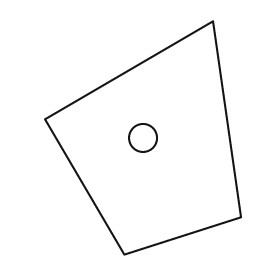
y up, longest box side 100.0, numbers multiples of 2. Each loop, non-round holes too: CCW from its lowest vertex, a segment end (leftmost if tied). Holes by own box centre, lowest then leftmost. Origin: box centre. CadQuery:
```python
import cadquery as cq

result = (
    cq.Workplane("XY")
    .moveTo(-8.0, -50.0)
    .lineTo(42.0, -34.0)
    .lineTo(30.0, 50.0)
    .lineTo(-42.0, 8.0)
    .close()
    .moveTo(0.0, 0.0)
    .circle(6.0)
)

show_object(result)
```